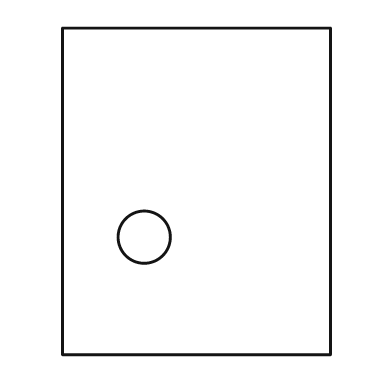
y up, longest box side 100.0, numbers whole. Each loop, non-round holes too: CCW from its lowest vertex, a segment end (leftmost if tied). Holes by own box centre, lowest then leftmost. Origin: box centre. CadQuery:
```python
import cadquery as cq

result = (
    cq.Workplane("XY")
    .moveTo(-41.0, -50.0)
    .lineTo(41.0, -50.0)
    .lineTo(41.0, 50.0)
    .lineTo(-41.0, 50.0)
    .close()
    .moveTo(-16.0, -14.0)
    .circle(8.0)
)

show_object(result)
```